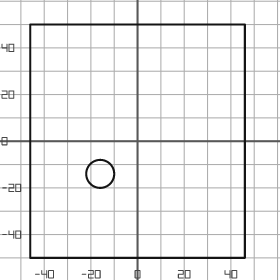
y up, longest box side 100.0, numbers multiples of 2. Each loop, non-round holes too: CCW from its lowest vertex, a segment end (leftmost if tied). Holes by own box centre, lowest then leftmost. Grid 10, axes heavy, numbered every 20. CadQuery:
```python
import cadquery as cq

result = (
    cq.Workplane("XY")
    .moveTo(-46.0, -50.0)
    .lineTo(46.0, -50.0)
    .lineTo(46.0, 50.0)
    .lineTo(-46.0, 50.0)
    .close()
    .moveTo(-16.0, -14.0)
    .circle(6.0)
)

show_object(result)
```